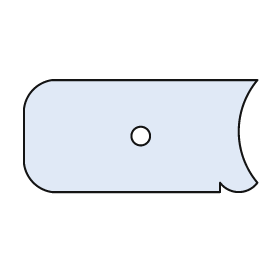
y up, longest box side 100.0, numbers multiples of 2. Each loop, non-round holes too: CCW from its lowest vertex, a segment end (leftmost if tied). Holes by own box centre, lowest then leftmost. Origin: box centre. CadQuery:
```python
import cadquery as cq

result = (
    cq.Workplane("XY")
    .moveTo(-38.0, -24.0)
    .lineTo(34.0, -24.0)
    .lineTo(34.0, -20.0)
    .threePointArc((42.0, -24.0), (50.0, -20.0))
    .threePointArc((42.0, 2.0), (50.0, 24.0))
    .lineTo(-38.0, 24.0)
    .threePointArc((-46.0, 20.0), (-50.0, 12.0))
    .lineTo(-50.0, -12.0)
    .threePointArc((-46.0, -20.0), (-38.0, -24.0))
    .close()
    .moveTo(0.0, 0.0)
    .circle(4.0)
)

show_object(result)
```